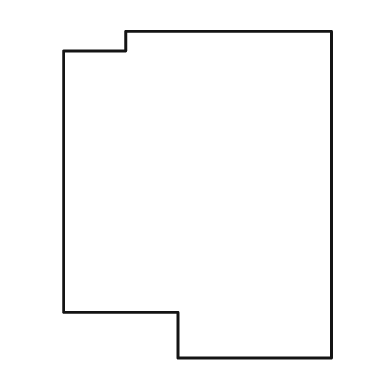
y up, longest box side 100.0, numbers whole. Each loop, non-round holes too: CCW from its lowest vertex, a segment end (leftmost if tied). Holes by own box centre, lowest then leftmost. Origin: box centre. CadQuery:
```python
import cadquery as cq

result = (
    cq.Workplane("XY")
    .moveTo(-6.0, -50.0)
    .lineTo(41.0, -50.0)
    .lineTo(41.0, 50.0)
    .lineTo(-22.0, 50.0)
    .lineTo(-22.0, 44.0)
    .lineTo(-41.0, 44.0)
    .lineTo(-41.0, -36.0)
    .lineTo(-6.0, -36.0)
    .close()
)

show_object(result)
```